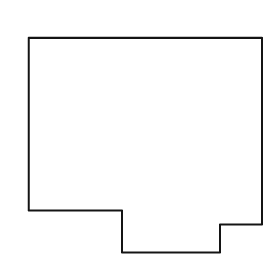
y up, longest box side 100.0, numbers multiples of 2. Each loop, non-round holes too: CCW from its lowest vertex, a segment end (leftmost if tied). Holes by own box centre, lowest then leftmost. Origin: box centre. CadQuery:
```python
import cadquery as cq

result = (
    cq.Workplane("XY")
    .moveTo(-10.0, -46.0)
    .lineTo(32.0, -46.0)
    .lineTo(32.0, -34.0)
    .lineTo(50.0, -34.0)
    .lineTo(50.0, 46.0)
    .lineTo(-50.0, 46.0)
    .lineTo(-50.0, -28.0)
    .lineTo(-10.0, -28.0)
    .close()
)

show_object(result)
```